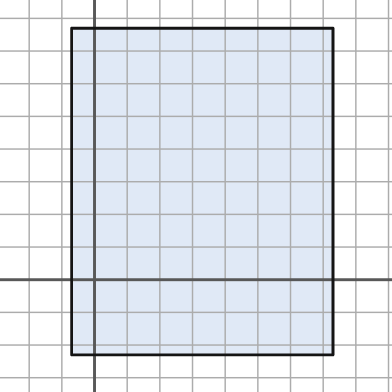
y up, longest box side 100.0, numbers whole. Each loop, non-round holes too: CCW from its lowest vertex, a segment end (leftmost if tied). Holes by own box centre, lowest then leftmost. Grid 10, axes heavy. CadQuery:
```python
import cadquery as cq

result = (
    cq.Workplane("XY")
    .moveTo(-7.0, -23.0)
    .lineTo(73.0, -23.0)
    .lineTo(73.0, 77.0)
    .lineTo(-7.0, 77.0)
    .close()
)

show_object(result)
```